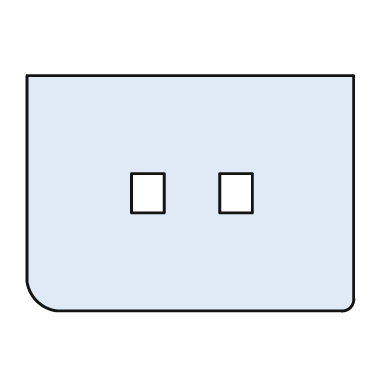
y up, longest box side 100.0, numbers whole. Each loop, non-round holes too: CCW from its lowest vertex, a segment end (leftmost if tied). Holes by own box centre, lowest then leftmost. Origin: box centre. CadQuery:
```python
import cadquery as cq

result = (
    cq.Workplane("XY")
    .moveTo(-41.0, -36.0)
    .lineTo(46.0, -36.0)
    .threePointArc((49.0, -35.0), (50.0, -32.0))
    .lineTo(50.0, 36.0)
    .lineTo(-50.0, 36.0)
    .lineTo(-50.0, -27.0)
    .threePointArc((-47.0, -33.0), (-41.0, -36.0))
    .close()
    .moveTo(-18.0, -6.0)
    .lineTo(-8.0, -6.0)
    .lineTo(-8.0, 6.0)
    .lineTo(-18.0, 6.0)
    .close()
    .moveTo(9.0, -6.0)
    .lineTo(19.0, -6.0)
    .lineTo(19.0, 6.0)
    .lineTo(9.0, 6.0)
    .close()
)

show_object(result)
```